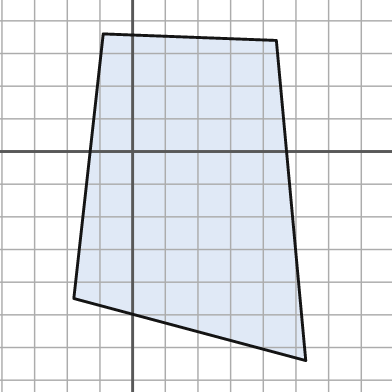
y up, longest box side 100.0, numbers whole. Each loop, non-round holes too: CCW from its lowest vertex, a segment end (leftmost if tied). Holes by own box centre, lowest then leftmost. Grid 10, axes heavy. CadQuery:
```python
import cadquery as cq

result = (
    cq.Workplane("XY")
    .moveTo(53.0, -64.0)
    .lineTo(44.0, 34.0)
    .lineTo(-9.0, 36.0)
    .lineTo(-18.0, -45.0)
    .close()
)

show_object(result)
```